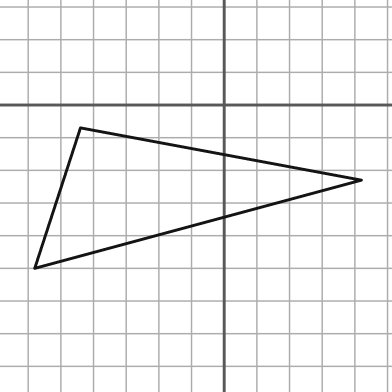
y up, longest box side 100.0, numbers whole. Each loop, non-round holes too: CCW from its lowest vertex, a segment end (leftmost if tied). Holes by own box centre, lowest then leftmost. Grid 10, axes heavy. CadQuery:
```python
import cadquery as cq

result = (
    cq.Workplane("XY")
    .moveTo(-58.0, -50.0)
    .lineTo(42.0, -23.0)
    .lineTo(-44.0, -7.0)
    .close()
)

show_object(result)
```